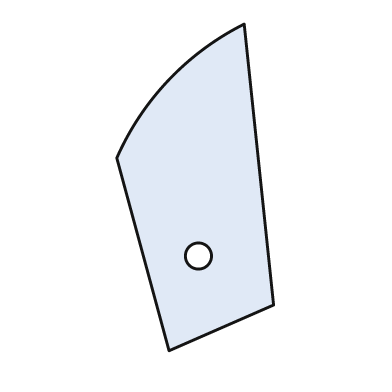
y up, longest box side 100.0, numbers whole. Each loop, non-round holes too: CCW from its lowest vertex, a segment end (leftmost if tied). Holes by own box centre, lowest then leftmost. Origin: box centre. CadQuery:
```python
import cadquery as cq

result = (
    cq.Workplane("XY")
    .moveTo(-8.0, -50.0)
    .lineTo(24.0, -36.0)
    .lineTo(15.0, 50.0)
    .threePointArc((-8.0, 33.0), (-24.0, 9.0))
    .close()
    .moveTo(1.0, -21.0)
    .circle(4.0)
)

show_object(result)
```